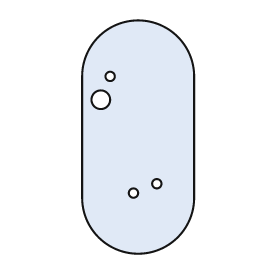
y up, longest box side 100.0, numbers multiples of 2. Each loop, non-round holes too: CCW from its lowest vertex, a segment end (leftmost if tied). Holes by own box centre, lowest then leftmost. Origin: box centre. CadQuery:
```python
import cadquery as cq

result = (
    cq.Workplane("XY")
    .moveTo(-24.0, -26.0)
    .threePointArc((0.0, -50.0), (24.0, -26.0))
    .lineTo(24.0, 26.0)
    .threePointArc((0.0, 50.0), (-24.0, 26.0))
    .close()
    .moveTo(-2.0, -24.0)
    .circle(2.0)
    .moveTo(8.0, -20.0)
    .circle(2.0)
    .moveTo(-16.0, 16.0)
    .circle(4.0)
    .moveTo(-12.0, 26.0)
    .circle(2.0)
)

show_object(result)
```